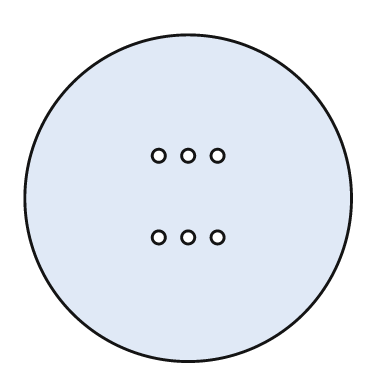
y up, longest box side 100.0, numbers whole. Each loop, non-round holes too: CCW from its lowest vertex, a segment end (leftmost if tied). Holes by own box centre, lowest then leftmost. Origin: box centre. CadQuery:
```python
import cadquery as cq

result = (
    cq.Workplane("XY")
    .moveTo(0.0, 0.0)
    .circle(50.0)
    .moveTo(-9.0, -12.0)
    .circle(2.0)
    .moveTo(0.0, -12.0)
    .circle(2.0)
    .moveTo(9.0, -12.0)
    .circle(2.0)
    .moveTo(-9.0, 13.0)
    .circle(2.0)
    .moveTo(0.0, 13.0)
    .circle(2.0)
    .moveTo(9.0, 13.0)
    .circle(2.0)
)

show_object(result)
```